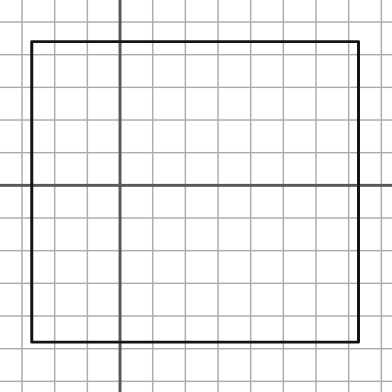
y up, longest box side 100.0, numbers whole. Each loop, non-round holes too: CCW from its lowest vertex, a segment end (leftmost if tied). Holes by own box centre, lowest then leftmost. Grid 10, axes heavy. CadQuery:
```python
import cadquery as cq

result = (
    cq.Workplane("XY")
    .moveTo(-27.0, -48.0)
    .lineTo(73.0, -48.0)
    .lineTo(73.0, 44.0)
    .lineTo(-27.0, 44.0)
    .close()
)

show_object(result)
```